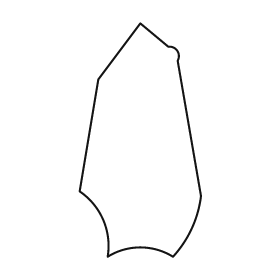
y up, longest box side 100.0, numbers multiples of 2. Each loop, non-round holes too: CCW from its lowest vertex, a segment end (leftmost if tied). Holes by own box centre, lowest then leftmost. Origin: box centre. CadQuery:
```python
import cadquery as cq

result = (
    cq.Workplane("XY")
    .moveTo(-14.0, -50.0)
    .threePointArc((0.0, -46.0), (14.0, -50.0))
    .threePointArc((22.0, -38.0), (26.0, -24.0))
    .lineTo(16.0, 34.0)
    .threePointArc((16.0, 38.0), (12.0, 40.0))
    .lineTo(0.0, 50.0)
    .lineTo(-18.0, 26.0)
    .lineTo(-26.0, -22.0)
    .threePointArc((-16.0, -34.0), (-14.0, -50.0))
    .close()
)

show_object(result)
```